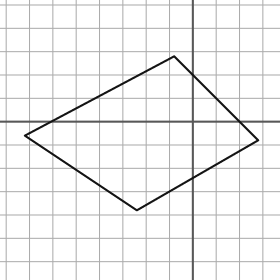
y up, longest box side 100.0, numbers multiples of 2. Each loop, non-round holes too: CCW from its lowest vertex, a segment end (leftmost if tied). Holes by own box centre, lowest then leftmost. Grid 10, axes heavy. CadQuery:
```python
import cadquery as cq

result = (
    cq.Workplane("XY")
    .moveTo(-24.0, -38.0)
    .lineTo(28.0, -8.0)
    .lineTo(-8.0, 28.0)
    .lineTo(-72.0, -6.0)
    .close()
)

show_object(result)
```